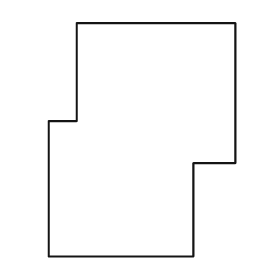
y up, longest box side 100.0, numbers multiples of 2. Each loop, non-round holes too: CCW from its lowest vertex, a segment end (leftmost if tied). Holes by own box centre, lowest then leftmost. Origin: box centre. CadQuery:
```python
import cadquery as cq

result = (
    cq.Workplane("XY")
    .moveTo(-40.0, -50.0)
    .lineTo(22.0, -50.0)
    .lineTo(22.0, -10.0)
    .lineTo(40.0, -10.0)
    .lineTo(40.0, 50.0)
    .lineTo(-28.0, 50.0)
    .lineTo(-28.0, 8.0)
    .lineTo(-40.0, 8.0)
    .close()
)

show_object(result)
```